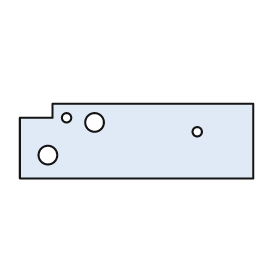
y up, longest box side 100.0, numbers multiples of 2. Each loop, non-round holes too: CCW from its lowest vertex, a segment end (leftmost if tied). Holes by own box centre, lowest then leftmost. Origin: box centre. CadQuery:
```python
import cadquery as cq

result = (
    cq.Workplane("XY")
    .moveTo(-50.0, -16.0)
    .lineTo(50.0, -16.0)
    .lineTo(50.0, 16.0)
    .lineTo(-36.0, 16.0)
    .lineTo(-36.0, 10.0)
    .lineTo(-50.0, 10.0)
    .close()
    .moveTo(-38.0, -6.0)
    .circle(4.0)
    .moveTo(26.0, 4.0)
    .circle(2.0)
    .moveTo(-18.0, 8.0)
    .circle(4.0)
    .moveTo(-30.0, 10.0)
    .circle(2.0)
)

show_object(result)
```